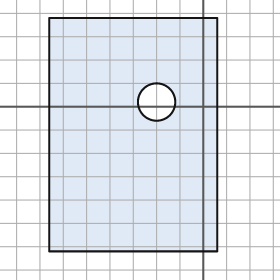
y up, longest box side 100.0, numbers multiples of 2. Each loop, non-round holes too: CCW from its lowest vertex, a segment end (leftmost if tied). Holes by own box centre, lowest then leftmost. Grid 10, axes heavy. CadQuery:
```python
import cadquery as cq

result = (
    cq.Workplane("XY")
    .moveTo(-66.0, -62.0)
    .lineTo(6.0, -62.0)
    .lineTo(6.0, 38.0)
    .lineTo(-66.0, 38.0)
    .close()
    .moveTo(-20.0, 2.0)
    .circle(8.0)
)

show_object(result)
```